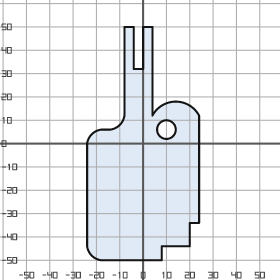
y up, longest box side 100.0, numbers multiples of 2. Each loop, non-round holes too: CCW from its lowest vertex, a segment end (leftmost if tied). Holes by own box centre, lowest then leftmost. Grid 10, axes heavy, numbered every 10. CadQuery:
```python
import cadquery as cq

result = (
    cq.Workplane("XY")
    .moveTo(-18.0, -50.0)
    .lineTo(8.0, -50.0)
    .lineTo(8.0, -44.0)
    .lineTo(20.0, -44.0)
    .lineTo(20.0, -34.0)
    .lineTo(24.0, -34.0)
    .lineTo(24.0, 12.0)
    .threePointArc((14.0, 18.0), (4.0, 12.0))
    .lineTo(4.0, 50.0)
    .lineTo(0.0, 50.0)
    .lineTo(0.0, 32.0)
    .lineTo(-4.0, 32.0)
    .lineTo(-4.0, 50.0)
    .lineTo(-8.0, 50.0)
    .lineTo(-8.0, 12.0)
    .threePointArc((-10.0, 8.0), (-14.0, 6.0))
    .lineTo(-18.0, 6.0)
    .threePointArc((-22.0, 4.0), (-24.0, 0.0))
    .lineTo(-24.0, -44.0)
    .threePointArc((-22.0, -48.0), (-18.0, -50.0))
    .close()
    .moveTo(10.0, 6.0)
    .circle(4.0)
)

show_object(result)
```